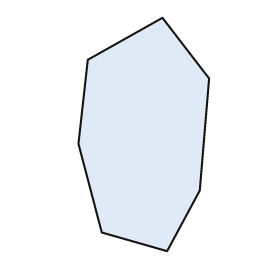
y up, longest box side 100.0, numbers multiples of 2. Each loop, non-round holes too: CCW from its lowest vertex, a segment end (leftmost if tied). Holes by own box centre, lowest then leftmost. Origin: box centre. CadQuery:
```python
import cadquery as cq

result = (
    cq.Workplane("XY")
    .moveTo(10.0, -50.0)
    .lineTo(24.0, -24.0)
    .lineTo(28.0, 24.0)
    .lineTo(8.0, 50.0)
    .lineTo(-24.0, 32.0)
    .lineTo(-28.0, -4.0)
    .lineTo(-18.0, -42.0)
    .close()
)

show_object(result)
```